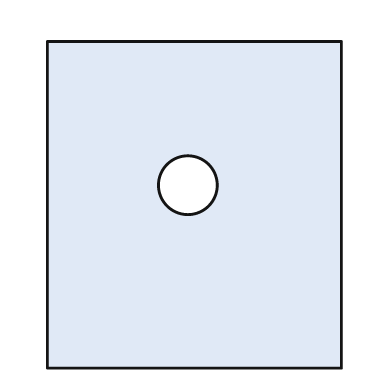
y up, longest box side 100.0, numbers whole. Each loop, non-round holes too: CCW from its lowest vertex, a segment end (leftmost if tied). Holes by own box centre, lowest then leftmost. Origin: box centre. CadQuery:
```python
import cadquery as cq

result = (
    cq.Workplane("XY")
    .moveTo(-45.0, -50.0)
    .lineTo(45.0, -50.0)
    .lineTo(45.0, 50.0)
    .lineTo(-45.0, 50.0)
    .close()
    .moveTo(-2.0, 6.0)
    .circle(9.0)
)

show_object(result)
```